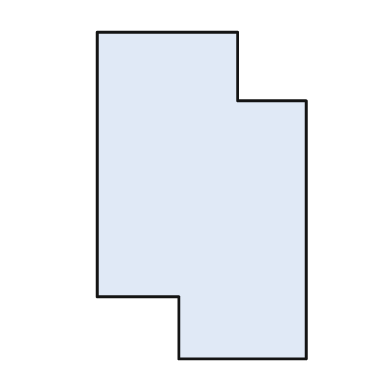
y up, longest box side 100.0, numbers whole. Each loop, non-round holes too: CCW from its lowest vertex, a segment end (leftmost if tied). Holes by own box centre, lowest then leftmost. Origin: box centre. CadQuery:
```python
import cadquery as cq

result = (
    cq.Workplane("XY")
    .moveTo(-7.0, -50.0)
    .lineTo(32.0, -50.0)
    .lineTo(32.0, 29.0)
    .lineTo(11.0, 29.0)
    .lineTo(11.0, 50.0)
    .lineTo(-32.0, 50.0)
    .lineTo(-32.0, -31.0)
    .lineTo(-7.0, -31.0)
    .close()
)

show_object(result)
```